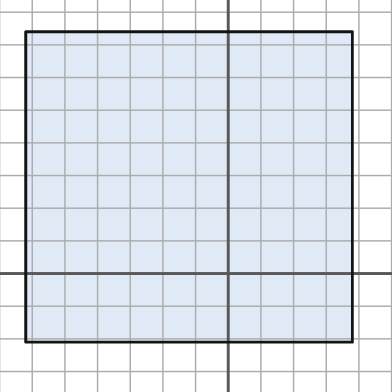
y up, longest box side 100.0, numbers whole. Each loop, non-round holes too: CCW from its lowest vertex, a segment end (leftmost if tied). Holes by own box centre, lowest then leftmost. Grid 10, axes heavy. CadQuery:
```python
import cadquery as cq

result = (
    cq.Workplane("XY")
    .moveTo(-62.0, -21.0)
    .lineTo(38.0, -21.0)
    .lineTo(38.0, 74.0)
    .lineTo(-62.0, 74.0)
    .close()
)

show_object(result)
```